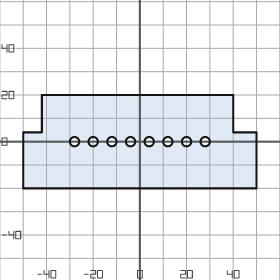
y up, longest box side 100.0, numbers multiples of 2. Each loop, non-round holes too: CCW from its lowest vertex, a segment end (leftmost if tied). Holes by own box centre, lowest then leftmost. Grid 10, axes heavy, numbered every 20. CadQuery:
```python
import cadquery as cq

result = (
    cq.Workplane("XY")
    .moveTo(-50.0, -20.0)
    .lineTo(50.0, -20.0)
    .lineTo(50.0, 4.0)
    .lineTo(40.0, 4.0)
    .lineTo(40.0, 20.0)
    .lineTo(-42.0, 20.0)
    .lineTo(-42.0, 4.0)
    .lineTo(-50.0, 4.0)
    .close()
    .moveTo(-28.0, 0.0)
    .circle(2.0)
    .moveTo(-20.0, 0.0)
    .circle(2.0)
    .moveTo(-12.0, 0.0)
    .circle(2.0)
    .moveTo(-4.0, 0.0)
    .circle(2.0)
    .moveTo(4.0, 0.0)
    .circle(2.0)
    .moveTo(12.0, 0.0)
    .circle(2.0)
    .moveTo(20.0, 0.0)
    .circle(2.0)
    .moveTo(28.0, 0.0)
    .circle(2.0)
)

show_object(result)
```